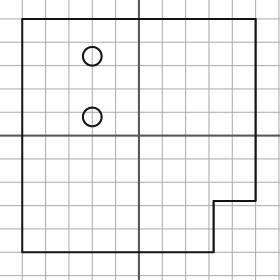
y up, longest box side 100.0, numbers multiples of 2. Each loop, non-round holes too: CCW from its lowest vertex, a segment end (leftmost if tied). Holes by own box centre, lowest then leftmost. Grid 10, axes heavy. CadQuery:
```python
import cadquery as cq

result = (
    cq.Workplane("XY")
    .moveTo(-50.0, -50.0)
    .lineTo(32.0, -50.0)
    .lineTo(32.0, -28.0)
    .lineTo(50.0, -28.0)
    .lineTo(50.0, 50.0)
    .lineTo(-50.0, 50.0)
    .close()
    .moveTo(-20.0, 8.0)
    .circle(4.0)
    .moveTo(-20.0, 34.0)
    .circle(4.0)
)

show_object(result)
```